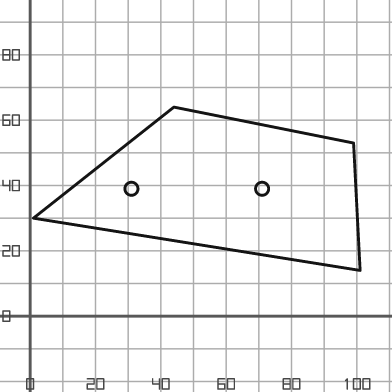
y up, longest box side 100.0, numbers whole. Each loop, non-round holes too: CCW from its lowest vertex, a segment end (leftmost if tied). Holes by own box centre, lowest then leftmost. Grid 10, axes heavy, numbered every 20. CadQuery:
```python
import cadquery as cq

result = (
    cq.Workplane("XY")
    .moveTo(101.0, 14.0)
    .lineTo(99.0, 53.0)
    .lineTo(44.0, 64.0)
    .lineTo(1.0, 30.0)
    .close()
    .moveTo(31.0, 39.0)
    .circle(2.0)
    .moveTo(71.0, 39.0)
    .circle(2.0)
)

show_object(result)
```